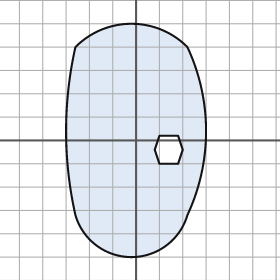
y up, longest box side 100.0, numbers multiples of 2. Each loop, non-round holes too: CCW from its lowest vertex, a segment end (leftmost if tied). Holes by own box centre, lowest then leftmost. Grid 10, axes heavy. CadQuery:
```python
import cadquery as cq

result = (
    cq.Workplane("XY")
    .moveTo(-26.0, -32.0)
    .threePointArc((-2.0, -50.0), (22.0, -32.0))
    .threePointArc((30.0, 4.0), (22.0, 40.0))
    .threePointArc((-2.0, 50.0), (-26.0, 40.0))
    .threePointArc((-30.0, 4.0), (-26.0, -32.0))
    .close()
    .moveTo(10.0, -10.0)
    .lineTo(18.0, -10.0)
    .lineTo(20.0, -4.0)
    .lineTo(18.0, 2.0)
    .lineTo(10.0, 2.0)
    .lineTo(8.0, -4.0)
    .close()
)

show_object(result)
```